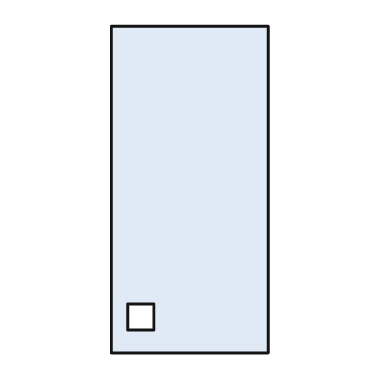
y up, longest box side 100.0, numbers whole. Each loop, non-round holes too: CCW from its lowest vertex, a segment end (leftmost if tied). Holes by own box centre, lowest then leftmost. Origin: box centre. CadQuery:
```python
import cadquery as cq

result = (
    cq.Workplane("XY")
    .moveTo(-24.0, -50.0)
    .lineTo(24.0, -50.0)
    .lineTo(24.0, 50.0)
    .lineTo(-24.0, 50.0)
    .close()
    .moveTo(-19.0, -43.0)
    .lineTo(-11.0, -43.0)
    .lineTo(-11.0, -35.0)
    .lineTo(-19.0, -35.0)
    .close()
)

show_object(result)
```